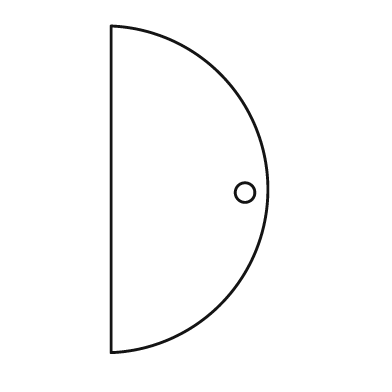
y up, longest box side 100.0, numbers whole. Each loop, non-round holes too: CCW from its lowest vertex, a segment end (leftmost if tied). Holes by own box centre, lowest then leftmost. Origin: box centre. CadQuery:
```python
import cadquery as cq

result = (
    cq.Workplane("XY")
    .moveTo(-24.0, -50.0)
    .threePointArc((24.0, 0.0), (-24.0, 50.0))
    .close()
    .moveTo(17.0, -1.0)
    .circle(3.0)
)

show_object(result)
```